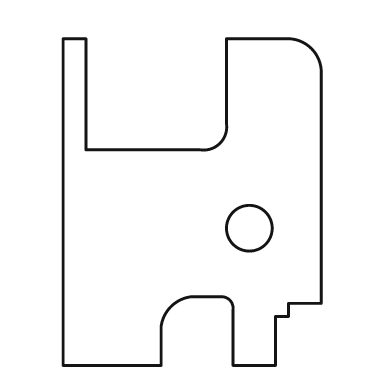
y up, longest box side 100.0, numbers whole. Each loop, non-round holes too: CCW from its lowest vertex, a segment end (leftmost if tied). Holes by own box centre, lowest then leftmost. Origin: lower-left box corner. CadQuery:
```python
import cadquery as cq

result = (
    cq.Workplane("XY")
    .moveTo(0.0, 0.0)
    .lineTo(30.0, 0.0)
    .lineTo(30.0, 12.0)
    .threePointArc((33.0, 18.0), (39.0, 21.0))
    .lineTo(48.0, 21.0)
    .threePointArc((51.0, 20.0), (52.0, 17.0))
    .lineTo(52.0, 0.0)
    .lineTo(65.0, 0.0)
    .lineTo(65.0, 15.0)
    .lineTo(69.0, 15.0)
    .lineTo(69.0, 19.0)
    .lineTo(79.0, 19.0)
    .lineTo(79.0, 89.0)
    .threePointArc((76.0, 97.0), (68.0, 100.0))
    .lineTo(50.0, 100.0)
    .lineTo(50.0, 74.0)
    .threePointArc((48.0, 68.0), (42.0, 66.0))
    .lineTo(7.0, 66.0)
    .lineTo(7.0, 100.0)
    .lineTo(0.0, 100.0)
    .close()
    .moveTo(57.0, 42.0)
    .circle(7.0)
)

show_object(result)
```